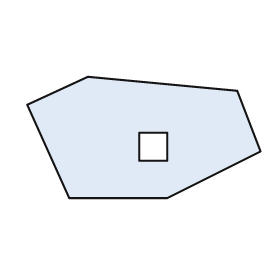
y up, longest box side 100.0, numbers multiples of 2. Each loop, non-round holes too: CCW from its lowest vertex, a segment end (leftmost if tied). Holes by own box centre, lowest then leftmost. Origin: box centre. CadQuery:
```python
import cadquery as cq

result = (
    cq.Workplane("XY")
    .moveTo(-32.0, -26.0)
    .lineTo(10.0, -26.0)
    .lineTo(50.0, -6.0)
    .lineTo(40.0, 20.0)
    .lineTo(-24.0, 26.0)
    .lineTo(-50.0, 14.0)
    .close()
    .moveTo(-2.0, -10.0)
    .lineTo(10.0, -10.0)
    .lineTo(10.0, 2.0)
    .lineTo(-2.0, 2.0)
    .close()
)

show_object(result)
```